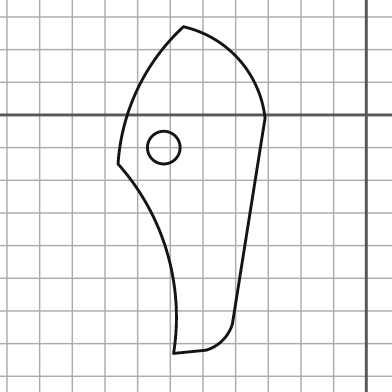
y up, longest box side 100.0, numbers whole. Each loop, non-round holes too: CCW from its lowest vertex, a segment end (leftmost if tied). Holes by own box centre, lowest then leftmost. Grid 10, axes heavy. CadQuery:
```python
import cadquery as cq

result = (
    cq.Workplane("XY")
    .moveTo(-59.0, -73.0)
    .lineTo(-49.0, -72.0)
    .threePointArc((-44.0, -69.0), (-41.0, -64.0))
    .lineTo(-31.0, -1.0)
    .threePointArc((-39.0, 17.0), (-56.0, 27.0))
    .threePointArc((-70.0, 8.0), (-76.0, -15.0))
    .threePointArc((-61.0, -42.0), (-59.0, -73.0))
    .close()
    .moveTo(-62.0, -10.0)
    .circle(5.0)
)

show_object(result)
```